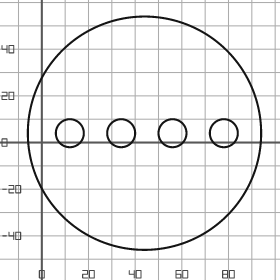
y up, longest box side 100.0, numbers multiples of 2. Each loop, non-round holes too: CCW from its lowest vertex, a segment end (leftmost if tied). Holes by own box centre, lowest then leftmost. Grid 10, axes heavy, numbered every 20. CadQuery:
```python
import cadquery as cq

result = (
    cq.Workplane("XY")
    .moveTo(44.0, 4.0)
    .circle(50.0)
    .moveTo(12.0, 4.0)
    .circle(6.0)
    .moveTo(34.0, 4.0)
    .circle(6.0)
    .moveTo(56.0, 4.0)
    .circle(6.0)
    .moveTo(78.0, 4.0)
    .circle(6.0)
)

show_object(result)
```